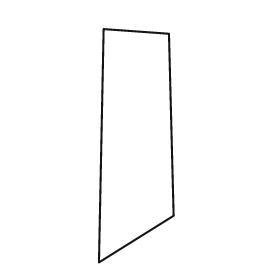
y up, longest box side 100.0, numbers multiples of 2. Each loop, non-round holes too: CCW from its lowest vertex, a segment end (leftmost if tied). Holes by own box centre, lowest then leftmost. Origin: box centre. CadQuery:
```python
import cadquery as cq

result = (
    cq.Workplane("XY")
    .moveTo(-16.0, -50.0)
    .lineTo(16.0, -30.0)
    .lineTo(14.0, 48.0)
    .lineTo(-14.0, 50.0)
    .close()
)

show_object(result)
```